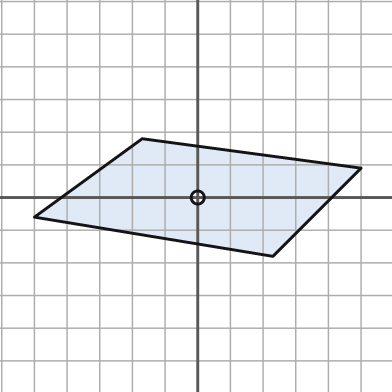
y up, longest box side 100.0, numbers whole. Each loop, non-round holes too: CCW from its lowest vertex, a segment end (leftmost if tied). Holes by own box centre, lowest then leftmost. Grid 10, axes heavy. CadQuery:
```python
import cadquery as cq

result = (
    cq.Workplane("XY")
    .moveTo(23.0, -18.0)
    .lineTo(50.0, 9.0)
    .lineTo(-17.0, 18.0)
    .lineTo(-50.0, -6.0)
    .close()
    .moveTo(0.0, 0.0)
    .circle(2.0)
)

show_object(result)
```